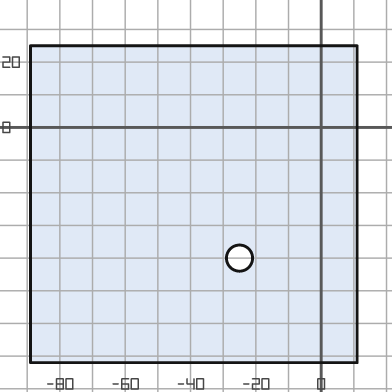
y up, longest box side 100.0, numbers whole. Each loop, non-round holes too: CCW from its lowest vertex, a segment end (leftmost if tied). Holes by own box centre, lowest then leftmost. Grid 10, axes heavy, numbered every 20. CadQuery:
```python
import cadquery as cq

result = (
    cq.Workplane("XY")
    .moveTo(-89.0, -72.0)
    .lineTo(11.0, -72.0)
    .lineTo(11.0, 25.0)
    .lineTo(-89.0, 25.0)
    .close()
    .moveTo(-25.0, -40.0)
    .circle(4.0)
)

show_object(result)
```